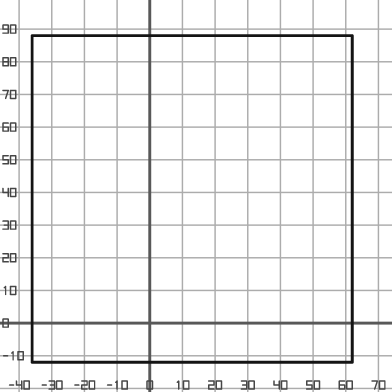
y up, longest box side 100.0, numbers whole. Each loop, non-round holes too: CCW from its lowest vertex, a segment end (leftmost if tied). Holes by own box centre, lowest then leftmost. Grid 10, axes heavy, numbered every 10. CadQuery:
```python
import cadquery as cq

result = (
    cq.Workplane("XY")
    .moveTo(-36.0, -12.0)
    .lineTo(62.0, -12.0)
    .lineTo(62.0, 88.0)
    .lineTo(-36.0, 88.0)
    .close()
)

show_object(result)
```